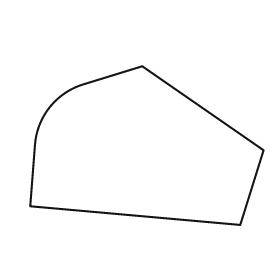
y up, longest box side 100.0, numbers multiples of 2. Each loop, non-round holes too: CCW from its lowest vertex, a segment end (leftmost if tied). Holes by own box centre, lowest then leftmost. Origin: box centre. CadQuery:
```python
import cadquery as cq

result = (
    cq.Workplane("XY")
    .moveTo(40.0, -34.0)
    .lineTo(50.0, -2.0)
    .lineTo(-2.0, 34.0)
    .lineTo(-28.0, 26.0)
    .threePointArc((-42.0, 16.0), (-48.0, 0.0))
    .lineTo(-50.0, -26.0)
    .close()
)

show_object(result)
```